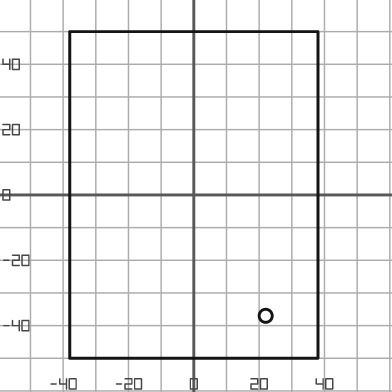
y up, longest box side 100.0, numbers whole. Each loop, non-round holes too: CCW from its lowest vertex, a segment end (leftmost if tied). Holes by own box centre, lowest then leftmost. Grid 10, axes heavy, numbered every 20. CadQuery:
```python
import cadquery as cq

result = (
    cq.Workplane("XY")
    .moveTo(-38.0, -50.0)
    .lineTo(38.0, -50.0)
    .lineTo(38.0, 50.0)
    .lineTo(-38.0, 50.0)
    .close()
    .moveTo(22.0, -37.0)
    .circle(2.0)
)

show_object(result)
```